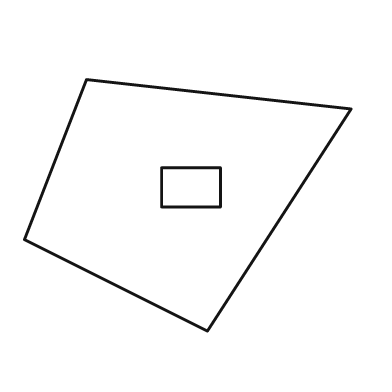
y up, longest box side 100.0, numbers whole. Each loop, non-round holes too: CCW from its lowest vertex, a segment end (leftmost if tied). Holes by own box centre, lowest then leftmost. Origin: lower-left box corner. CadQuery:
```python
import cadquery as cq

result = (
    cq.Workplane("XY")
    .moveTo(56.0, 0.0)
    .lineTo(100.0, 68.0)
    .lineTo(19.0, 77.0)
    .lineTo(0.0, 28.0)
    .close()
    .moveTo(42.0, 38.0)
    .lineTo(60.0, 38.0)
    .lineTo(60.0, 50.0)
    .lineTo(42.0, 50.0)
    .close()
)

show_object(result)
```